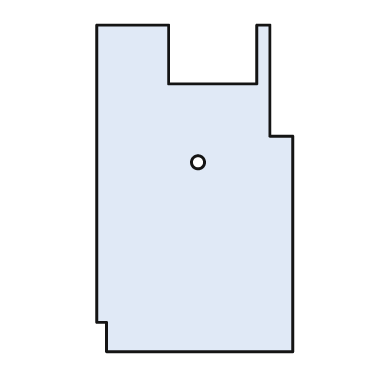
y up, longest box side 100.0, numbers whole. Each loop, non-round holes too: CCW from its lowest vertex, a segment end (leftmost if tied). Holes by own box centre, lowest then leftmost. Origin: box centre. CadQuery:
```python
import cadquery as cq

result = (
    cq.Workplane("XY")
    .moveTo(-27.0, -50.0)
    .lineTo(30.0, -50.0)
    .lineTo(30.0, 16.0)
    .lineTo(23.0, 16.0)
    .lineTo(23.0, 50.0)
    .lineTo(19.0, 50.0)
    .lineTo(19.0, 32.0)
    .lineTo(-8.0, 32.0)
    .lineTo(-8.0, 50.0)
    .lineTo(-30.0, 50.0)
    .lineTo(-30.0, -41.0)
    .lineTo(-27.0, -41.0)
    .close()
    .moveTo(1.0, 8.0)
    .circle(2.0)
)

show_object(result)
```